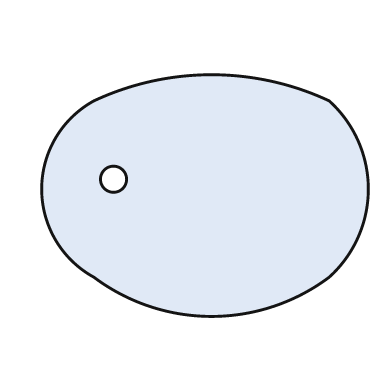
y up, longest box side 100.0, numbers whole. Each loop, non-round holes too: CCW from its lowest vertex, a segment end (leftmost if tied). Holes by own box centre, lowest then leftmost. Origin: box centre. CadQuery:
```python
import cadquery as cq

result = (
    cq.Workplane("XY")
    .moveTo(-34.0, -25.0)
    .threePointArc((2.0, -37.0), (38.0, -25.0))
    .threePointArc((50.0, 2.0), (38.0, 29.0))
    .threePointArc((2.0, 37.0), (-34.0, 29.0))
    .threePointArc((-50.0, 2.0), (-34.0, -25.0))
    .close()
    .moveTo(-28.0, 5.0)
    .circle(4.0)
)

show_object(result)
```